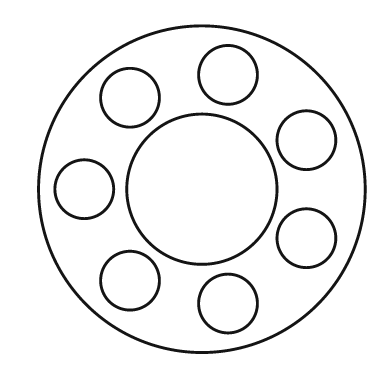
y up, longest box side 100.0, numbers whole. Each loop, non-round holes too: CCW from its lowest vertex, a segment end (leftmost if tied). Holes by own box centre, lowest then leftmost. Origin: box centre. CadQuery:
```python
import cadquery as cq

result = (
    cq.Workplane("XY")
    .moveTo(0.0, 0.0)
    .circle(50.0)
    .moveTo(8.0, -35.0)
    .circle(9.0)
    .moveTo(-22.0, -28.0)
    .circle(9.0)
    .moveTo(32.0, -15.0)
    .circle(9.0)
    .moveTo(-36.0, 0.0)
    .circle(9.0)
    .moveTo(0.0, 0.0)
    .circle(23.0)
    .moveTo(32.0, 15.0)
    .circle(9.0)
    .moveTo(-22.0, 28.0)
    .circle(9.0)
    .moveTo(8.0, 35.0)
    .circle(9.0)
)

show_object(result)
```